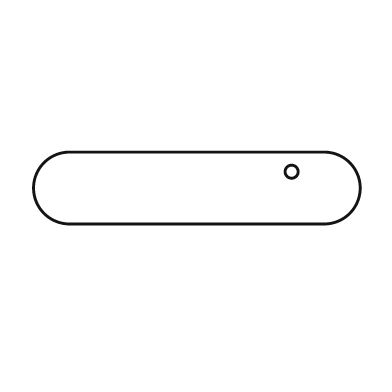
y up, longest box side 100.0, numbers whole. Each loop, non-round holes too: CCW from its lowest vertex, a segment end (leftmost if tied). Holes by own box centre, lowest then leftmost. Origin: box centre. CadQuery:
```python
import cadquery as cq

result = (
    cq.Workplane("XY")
    .moveTo(-39.0, -11.0)
    .lineTo(39.0, -11.0)
    .threePointArc((50.0, 0.0), (39.0, 11.0))
    .lineTo(-39.0, 11.0)
    .threePointArc((-50.0, 0.0), (-39.0, -11.0))
    .close()
    .moveTo(29.0, 5.0)
    .circle(2.0)
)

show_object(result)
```